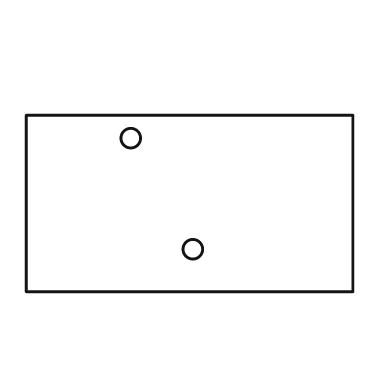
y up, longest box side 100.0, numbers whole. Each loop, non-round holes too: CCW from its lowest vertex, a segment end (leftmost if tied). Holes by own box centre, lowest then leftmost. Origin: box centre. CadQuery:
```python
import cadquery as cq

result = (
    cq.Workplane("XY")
    .moveTo(-50.0, -27.0)
    .lineTo(50.0, -27.0)
    .lineTo(50.0, 27.0)
    .lineTo(-50.0, 27.0)
    .close()
    .moveTo(1.0, -14.0)
    .circle(3.0)
    .moveTo(-18.0, 20.0)
    .circle(3.0)
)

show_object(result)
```